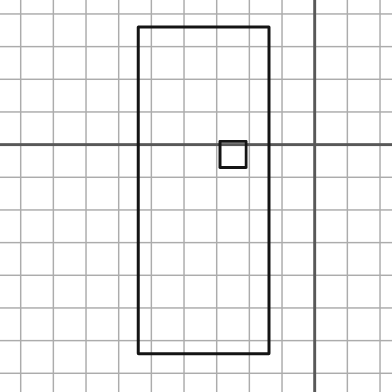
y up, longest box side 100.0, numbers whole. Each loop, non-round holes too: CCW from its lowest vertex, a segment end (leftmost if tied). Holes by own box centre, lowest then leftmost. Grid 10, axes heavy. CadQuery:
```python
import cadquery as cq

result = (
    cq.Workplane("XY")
    .moveTo(-54.0, -64.0)
    .lineTo(-14.0, -64.0)
    .lineTo(-14.0, 36.0)
    .lineTo(-54.0, 36.0)
    .close()
    .moveTo(-29.0, -7.0)
    .lineTo(-21.0, -7.0)
    .lineTo(-21.0, 1.0)
    .lineTo(-29.0, 1.0)
    .close()
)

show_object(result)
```